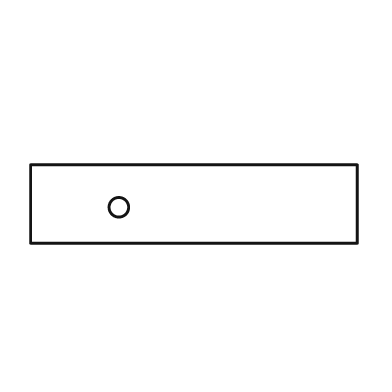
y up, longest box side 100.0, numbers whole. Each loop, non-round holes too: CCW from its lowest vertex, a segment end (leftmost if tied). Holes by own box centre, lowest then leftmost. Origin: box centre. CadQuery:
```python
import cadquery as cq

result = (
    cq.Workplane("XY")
    .moveTo(-50.0, -12.0)
    .lineTo(50.0, -12.0)
    .lineTo(50.0, 12.0)
    .lineTo(-50.0, 12.0)
    .close()
    .moveTo(-23.0, -1.0)
    .circle(3.0)
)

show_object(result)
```